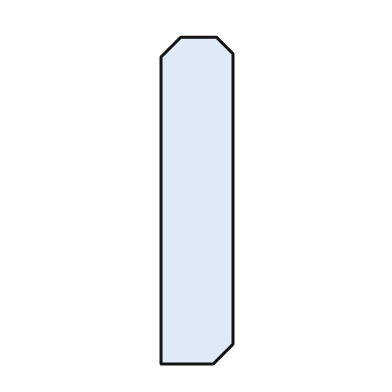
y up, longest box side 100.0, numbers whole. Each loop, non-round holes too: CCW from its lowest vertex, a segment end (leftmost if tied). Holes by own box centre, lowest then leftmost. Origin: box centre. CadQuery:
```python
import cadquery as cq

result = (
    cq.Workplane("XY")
    .moveTo(-11.0, -50.0)
    .lineTo(5.0, -50.0)
    .lineTo(11.0, -44.0)
    .lineTo(11.0, 45.0)
    .lineTo(6.0, 50.0)
    .lineTo(-5.0, 50.0)
    .lineTo(-11.0, 44.0)
    .close()
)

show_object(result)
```